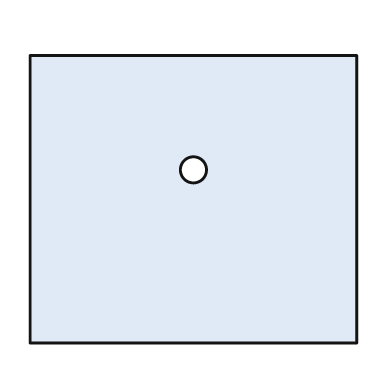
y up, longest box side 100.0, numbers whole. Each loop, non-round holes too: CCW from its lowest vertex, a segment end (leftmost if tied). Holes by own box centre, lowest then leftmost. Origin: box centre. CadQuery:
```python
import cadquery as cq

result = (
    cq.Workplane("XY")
    .moveTo(-50.0, -44.0)
    .lineTo(50.0, -44.0)
    .lineTo(50.0, 44.0)
    .lineTo(-50.0, 44.0)
    .close()
    .moveTo(0.0, 9.0)
    .circle(4.0)
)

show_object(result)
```